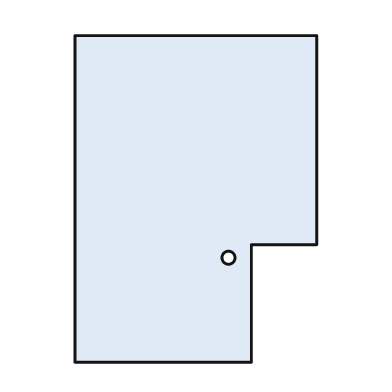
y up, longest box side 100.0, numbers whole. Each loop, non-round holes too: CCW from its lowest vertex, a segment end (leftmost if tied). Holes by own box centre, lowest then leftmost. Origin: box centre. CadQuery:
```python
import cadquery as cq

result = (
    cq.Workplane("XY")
    .moveTo(-37.0, -50.0)
    .lineTo(17.0, -50.0)
    .lineTo(17.0, -14.0)
    .lineTo(37.0, -14.0)
    .lineTo(37.0, 50.0)
    .lineTo(-37.0, 50.0)
    .close()
    .moveTo(10.0, -18.0)
    .circle(2.0)
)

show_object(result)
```